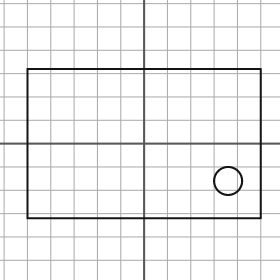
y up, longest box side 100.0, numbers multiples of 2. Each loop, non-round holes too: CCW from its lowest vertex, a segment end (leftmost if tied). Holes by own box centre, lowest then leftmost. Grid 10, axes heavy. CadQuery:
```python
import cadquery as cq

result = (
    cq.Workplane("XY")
    .moveTo(-50.0, -32.0)
    .lineTo(50.0, -32.0)
    .lineTo(50.0, 32.0)
    .lineTo(-50.0, 32.0)
    .close()
    .moveTo(36.0, -16.0)
    .circle(6.0)
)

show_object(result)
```